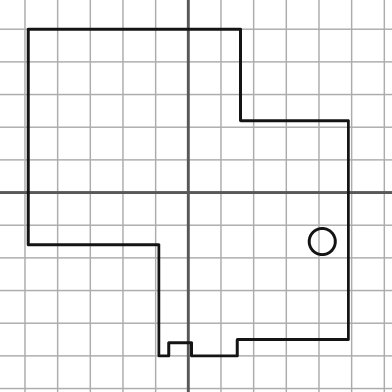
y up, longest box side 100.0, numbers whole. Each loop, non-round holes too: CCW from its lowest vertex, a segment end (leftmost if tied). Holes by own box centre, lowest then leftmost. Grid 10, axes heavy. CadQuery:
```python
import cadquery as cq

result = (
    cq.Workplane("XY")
    .moveTo(-9.0, -50.0)
    .lineTo(-6.0, -50.0)
    .lineTo(-6.0, -46.0)
    .lineTo(1.0, -46.0)
    .lineTo(1.0, -50.0)
    .lineTo(15.0, -50.0)
    .lineTo(15.0, -45.0)
    .lineTo(49.0, -45.0)
    .lineTo(49.0, 22.0)
    .lineTo(16.0, 22.0)
    .lineTo(16.0, 50.0)
    .lineTo(-49.0, 50.0)
    .lineTo(-49.0, -16.0)
    .lineTo(-9.0, -16.0)
    .close()
    .moveTo(41.0, -15.0)
    .circle(4.0)
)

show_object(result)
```